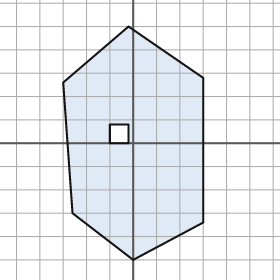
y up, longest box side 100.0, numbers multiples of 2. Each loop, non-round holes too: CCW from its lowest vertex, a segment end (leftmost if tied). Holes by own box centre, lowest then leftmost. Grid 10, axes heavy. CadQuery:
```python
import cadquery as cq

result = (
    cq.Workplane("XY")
    .moveTo(0.0, -50.0)
    .lineTo(30.0, -34.0)
    .lineTo(30.0, 28.0)
    .lineTo(-2.0, 50.0)
    .lineTo(-30.0, 26.0)
    .lineTo(-26.0, -30.0)
    .close()
    .moveTo(-10.0, 0.0)
    .lineTo(-2.0, 0.0)
    .lineTo(-2.0, 8.0)
    .lineTo(-10.0, 8.0)
    .close()
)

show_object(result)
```